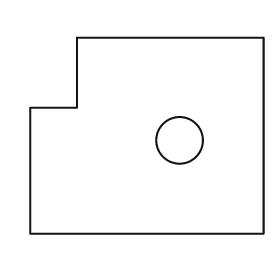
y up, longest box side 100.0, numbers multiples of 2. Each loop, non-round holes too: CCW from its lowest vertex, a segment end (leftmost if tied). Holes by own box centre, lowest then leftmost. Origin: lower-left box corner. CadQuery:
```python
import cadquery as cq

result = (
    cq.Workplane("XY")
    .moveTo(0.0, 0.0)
    .lineTo(100.0, 0.0)
    .lineTo(100.0, 84.0)
    .lineTo(20.0, 84.0)
    .lineTo(20.0, 54.0)
    .lineTo(0.0, 54.0)
    .close()
    .moveTo(64.0, 40.0)
    .circle(10.0)
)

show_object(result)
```